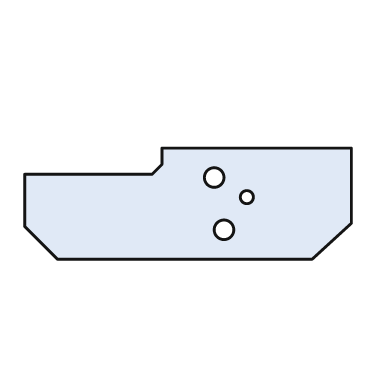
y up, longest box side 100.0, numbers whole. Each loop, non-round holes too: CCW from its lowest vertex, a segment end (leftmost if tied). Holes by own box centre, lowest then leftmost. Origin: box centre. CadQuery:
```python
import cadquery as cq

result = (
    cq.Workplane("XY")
    .moveTo(-40.0, -17.0)
    .lineTo(38.0, -17.0)
    .lineTo(50.0, -6.0)
    .lineTo(50.0, 17.0)
    .lineTo(-8.0, 17.0)
    .lineTo(-8.0, 12.0)
    .lineTo(-11.0, 9.0)
    .lineTo(-50.0, 9.0)
    .lineTo(-50.0, -7.0)
    .close()
    .moveTo(11.0, -8.0)
    .circle(3.0)
    .moveTo(18.0, 2.0)
    .circle(2.0)
    .moveTo(8.0, 8.0)
    .circle(3.0)
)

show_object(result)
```